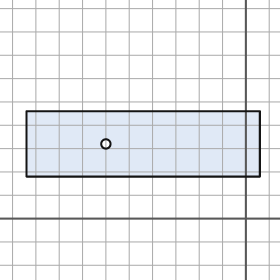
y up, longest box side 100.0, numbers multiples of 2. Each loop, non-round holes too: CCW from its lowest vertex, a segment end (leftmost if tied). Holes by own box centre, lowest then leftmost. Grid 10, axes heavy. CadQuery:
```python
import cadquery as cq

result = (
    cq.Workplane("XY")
    .moveTo(-94.0, 18.0)
    .lineTo(6.0, 18.0)
    .lineTo(6.0, 46.0)
    .lineTo(-94.0, 46.0)
    .close()
    .moveTo(-60.0, 32.0)
    .circle(2.0)
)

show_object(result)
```